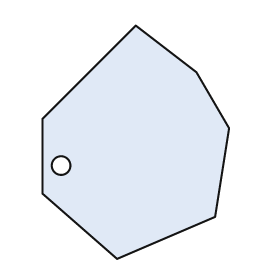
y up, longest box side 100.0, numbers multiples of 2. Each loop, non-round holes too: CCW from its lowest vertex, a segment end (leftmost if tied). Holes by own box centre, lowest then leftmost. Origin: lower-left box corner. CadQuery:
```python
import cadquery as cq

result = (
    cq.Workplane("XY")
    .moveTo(32.0, 0.0)
    .lineTo(74.0, 18.0)
    .lineTo(80.0, 56.0)
    .lineTo(66.0, 80.0)
    .lineTo(40.0, 100.0)
    .lineTo(0.0, 60.0)
    .lineTo(0.0, 28.0)
    .close()
    .moveTo(8.0, 40.0)
    .circle(4.0)
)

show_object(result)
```